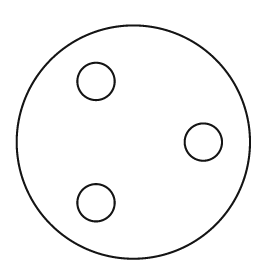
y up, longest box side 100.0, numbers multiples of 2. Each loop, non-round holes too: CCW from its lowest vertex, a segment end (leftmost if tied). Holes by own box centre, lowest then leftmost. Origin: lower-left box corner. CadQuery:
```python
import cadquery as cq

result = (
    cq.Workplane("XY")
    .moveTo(50.0, 50.0)
    .circle(50.0)
    .moveTo(34.0, 24.0)
    .circle(8.0)
    .moveTo(80.0, 50.0)
    .circle(8.0)
    .moveTo(34.0, 76.0)
    .circle(8.0)
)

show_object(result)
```